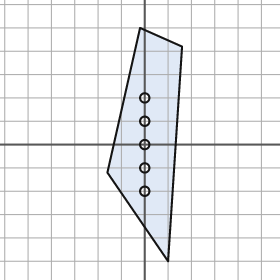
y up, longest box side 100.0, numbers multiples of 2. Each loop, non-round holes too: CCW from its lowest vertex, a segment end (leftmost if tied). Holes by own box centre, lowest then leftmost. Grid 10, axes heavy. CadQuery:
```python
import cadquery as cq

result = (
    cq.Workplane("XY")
    .moveTo(10.0, -50.0)
    .lineTo(16.0, 42.0)
    .lineTo(-2.0, 50.0)
    .lineTo(-16.0, -12.0)
    .close()
    .moveTo(0.0, -20.0)
    .circle(2.0)
    .moveTo(0.0, -10.0)
    .circle(2.0)
    .moveTo(0.0, 0.0)
    .circle(2.0)
    .moveTo(0.0, 10.0)
    .circle(2.0)
    .moveTo(0.0, 20.0)
    .circle(2.0)
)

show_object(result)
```